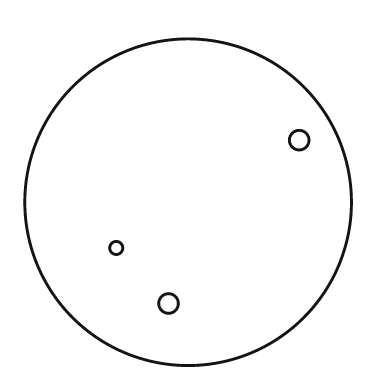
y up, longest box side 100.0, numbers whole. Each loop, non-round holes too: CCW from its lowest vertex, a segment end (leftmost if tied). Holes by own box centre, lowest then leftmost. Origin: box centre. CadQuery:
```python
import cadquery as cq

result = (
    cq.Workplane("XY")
    .moveTo(0.0, 0.0)
    .circle(50.0)
    .moveTo(-6.0, -31.0)
    .circle(3.0)
    .moveTo(-22.0, -14.0)
    .circle(2.0)
    .moveTo(34.0, 19.0)
    .circle(3.0)
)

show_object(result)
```